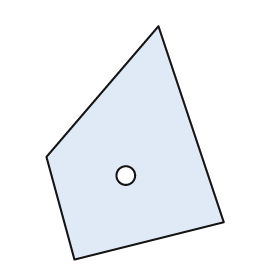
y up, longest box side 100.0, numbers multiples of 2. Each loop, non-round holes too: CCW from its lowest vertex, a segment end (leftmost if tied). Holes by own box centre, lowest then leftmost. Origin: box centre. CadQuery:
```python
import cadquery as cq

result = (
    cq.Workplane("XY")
    .moveTo(-26.0, -50.0)
    .lineTo(38.0, -34.0)
    .lineTo(10.0, 50.0)
    .lineTo(-38.0, -6.0)
    .close()
    .moveTo(-4.0, -14.0)
    .circle(4.0)
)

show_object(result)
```